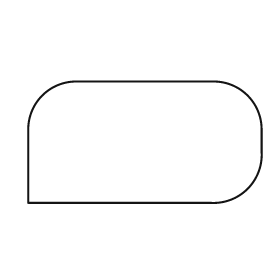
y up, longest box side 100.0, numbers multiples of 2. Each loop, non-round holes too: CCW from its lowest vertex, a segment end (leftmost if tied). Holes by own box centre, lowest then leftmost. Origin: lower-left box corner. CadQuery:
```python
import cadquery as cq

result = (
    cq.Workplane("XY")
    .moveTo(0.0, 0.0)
    .lineTo(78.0, 0.0)
    .threePointArc((94.0, 6.0), (100.0, 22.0))
    .lineTo(100.0, 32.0)
    .threePointArc((94.0, 46.0), (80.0, 52.0))
    .lineTo(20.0, 52.0)
    .threePointArc((6.0, 46.0), (0.0, 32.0))
    .close()
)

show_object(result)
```